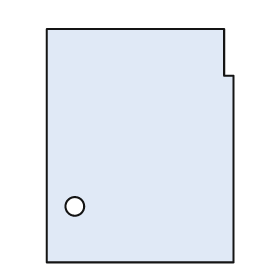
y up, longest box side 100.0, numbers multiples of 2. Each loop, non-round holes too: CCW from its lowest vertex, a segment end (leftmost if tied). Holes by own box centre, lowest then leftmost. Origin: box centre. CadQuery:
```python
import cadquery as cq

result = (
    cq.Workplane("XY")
    .moveTo(-40.0, -50.0)
    .lineTo(40.0, -50.0)
    .lineTo(40.0, 30.0)
    .lineTo(36.0, 30.0)
    .lineTo(36.0, 50.0)
    .lineTo(-40.0, 50.0)
    .close()
    .moveTo(-28.0, -26.0)
    .circle(4.0)
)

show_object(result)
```